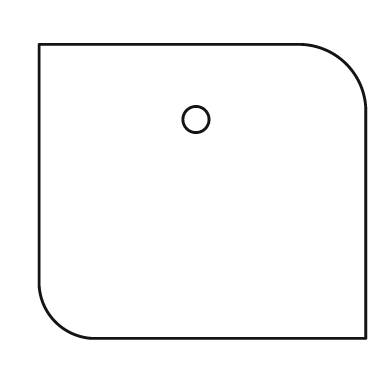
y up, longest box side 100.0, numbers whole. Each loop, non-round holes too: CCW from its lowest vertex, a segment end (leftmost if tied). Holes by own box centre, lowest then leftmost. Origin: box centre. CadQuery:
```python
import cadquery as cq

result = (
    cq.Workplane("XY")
    .moveTo(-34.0, -45.0)
    .lineTo(50.0, -45.0)
    .lineTo(50.0, 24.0)
    .threePointArc((44.0, 39.0), (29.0, 45.0))
    .lineTo(-50.0, 45.0)
    .lineTo(-50.0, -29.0)
    .threePointArc((-45.0, -40.0), (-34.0, -45.0))
    .close()
    .moveTo(-2.0, 22.0)
    .circle(4.0)
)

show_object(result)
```